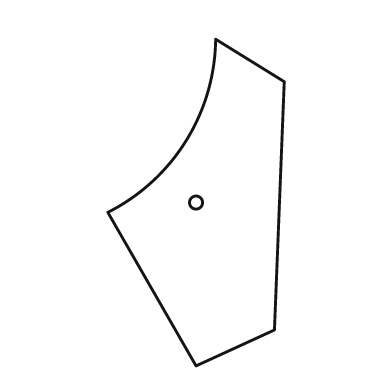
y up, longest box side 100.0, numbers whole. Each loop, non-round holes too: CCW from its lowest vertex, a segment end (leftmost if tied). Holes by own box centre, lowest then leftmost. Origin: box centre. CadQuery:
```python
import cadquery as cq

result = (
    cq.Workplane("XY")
    .moveTo(0.0, -50.0)
    .lineTo(24.0, -39.0)
    .lineTo(27.0, 37.0)
    .lineTo(6.0, 50.0)
    .threePointArc((-3.0, 19.0), (-27.0, -3.0))
    .close()
    .moveTo(0.0, 0.0)
    .circle(2.0)
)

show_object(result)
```